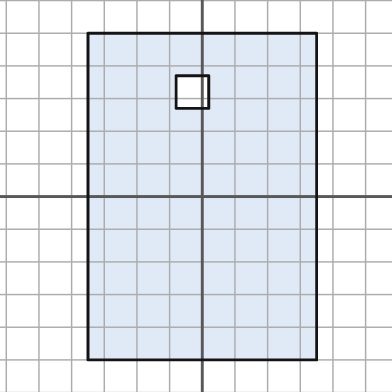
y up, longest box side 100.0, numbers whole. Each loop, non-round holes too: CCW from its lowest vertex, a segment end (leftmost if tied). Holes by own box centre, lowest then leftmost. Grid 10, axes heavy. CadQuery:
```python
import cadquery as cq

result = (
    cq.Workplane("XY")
    .moveTo(-35.0, -50.0)
    .lineTo(35.0, -50.0)
    .lineTo(35.0, 50.0)
    .lineTo(-35.0, 50.0)
    .close()
    .moveTo(-8.0, 27.0)
    .lineTo(2.0, 27.0)
    .lineTo(2.0, 37.0)
    .lineTo(-8.0, 37.0)
    .close()
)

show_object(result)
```